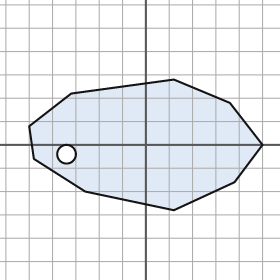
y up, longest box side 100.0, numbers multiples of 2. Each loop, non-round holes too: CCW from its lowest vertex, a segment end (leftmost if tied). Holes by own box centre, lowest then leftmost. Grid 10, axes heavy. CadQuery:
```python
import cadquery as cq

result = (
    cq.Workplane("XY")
    .moveTo(12.0, -28.0)
    .lineTo(38.0, -16.0)
    .lineTo(50.0, 0.0)
    .lineTo(36.0, 18.0)
    .lineTo(12.0, 28.0)
    .lineTo(-32.0, 22.0)
    .lineTo(-50.0, 8.0)
    .lineTo(-48.0, -6.0)
    .lineTo(-26.0, -20.0)
    .close()
    .moveTo(-34.0, -4.0)
    .circle(4.0)
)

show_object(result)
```